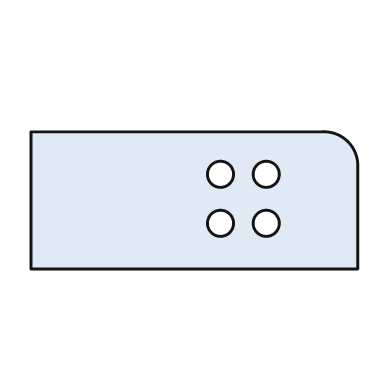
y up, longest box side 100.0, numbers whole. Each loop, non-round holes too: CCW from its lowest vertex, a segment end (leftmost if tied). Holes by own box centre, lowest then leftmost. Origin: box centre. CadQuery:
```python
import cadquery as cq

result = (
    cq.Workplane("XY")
    .moveTo(-50.0, -21.0)
    .lineTo(50.0, -21.0)
    .lineTo(50.0, 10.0)
    .threePointArc((47.0, 18.0), (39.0, 21.0))
    .lineTo(-50.0, 21.0)
    .close()
    .moveTo(8.0, -7.0)
    .circle(4.0)
    .moveTo(22.0, -7.0)
    .circle(4.0)
    .moveTo(8.0, 8.0)
    .circle(4.0)
    .moveTo(22.0, 8.0)
    .circle(4.0)
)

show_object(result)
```